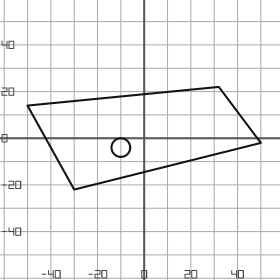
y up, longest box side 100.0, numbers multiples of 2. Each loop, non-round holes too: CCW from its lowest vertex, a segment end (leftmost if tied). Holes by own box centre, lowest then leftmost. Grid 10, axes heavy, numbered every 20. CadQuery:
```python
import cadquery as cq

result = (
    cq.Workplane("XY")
    .moveTo(-30.0, -22.0)
    .lineTo(50.0, -2.0)
    .lineTo(32.0, 22.0)
    .lineTo(-50.0, 14.0)
    .close()
    .moveTo(-10.0, -4.0)
    .circle(4.0)
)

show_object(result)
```